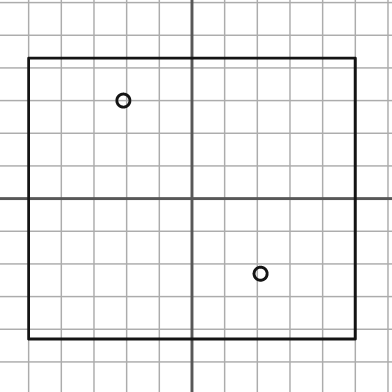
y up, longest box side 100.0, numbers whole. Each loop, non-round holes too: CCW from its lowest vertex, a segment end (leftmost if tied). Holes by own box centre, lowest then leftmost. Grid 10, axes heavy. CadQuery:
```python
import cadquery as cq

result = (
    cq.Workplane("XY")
    .moveTo(-50.0, -43.0)
    .lineTo(50.0, -43.0)
    .lineTo(50.0, 43.0)
    .lineTo(-50.0, 43.0)
    .close()
    .moveTo(21.0, -23.0)
    .circle(2.0)
    .moveTo(-21.0, 30.0)
    .circle(2.0)
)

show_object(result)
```